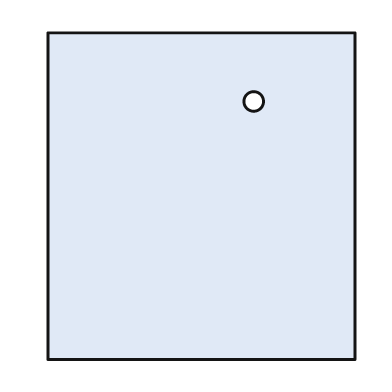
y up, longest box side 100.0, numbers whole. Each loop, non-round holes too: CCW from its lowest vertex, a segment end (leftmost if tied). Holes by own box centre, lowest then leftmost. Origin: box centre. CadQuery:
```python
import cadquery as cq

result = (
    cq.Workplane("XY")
    .moveTo(-47.0, -50.0)
    .lineTo(47.0, -50.0)
    .lineTo(47.0, 50.0)
    .lineTo(-47.0, 50.0)
    .close()
    .moveTo(16.0, 29.0)
    .circle(3.0)
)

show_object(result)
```